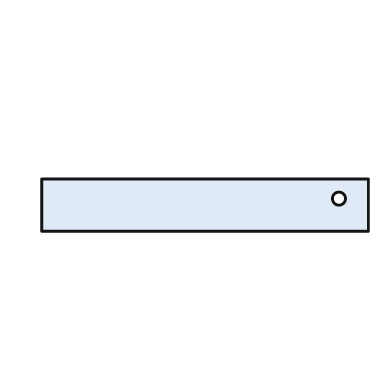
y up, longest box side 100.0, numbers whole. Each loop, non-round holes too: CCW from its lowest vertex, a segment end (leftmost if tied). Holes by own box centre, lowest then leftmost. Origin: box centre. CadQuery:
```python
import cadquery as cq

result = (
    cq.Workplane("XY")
    .moveTo(-50.0, -8.0)
    .lineTo(50.0, -8.0)
    .lineTo(50.0, 8.0)
    .lineTo(-50.0, 8.0)
    .close()
    .moveTo(41.0, 2.0)
    .circle(2.0)
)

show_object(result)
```